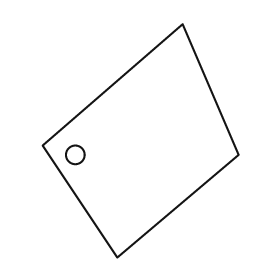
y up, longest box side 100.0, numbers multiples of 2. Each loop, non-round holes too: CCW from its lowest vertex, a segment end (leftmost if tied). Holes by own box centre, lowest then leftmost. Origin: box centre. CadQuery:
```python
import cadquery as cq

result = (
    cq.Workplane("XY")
    .moveTo(-10.0, -50.0)
    .lineTo(42.0, -6.0)
    .lineTo(18.0, 50.0)
    .lineTo(-42.0, -2.0)
    .close()
    .moveTo(-28.0, -6.0)
    .circle(4.0)
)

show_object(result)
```